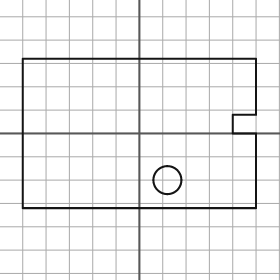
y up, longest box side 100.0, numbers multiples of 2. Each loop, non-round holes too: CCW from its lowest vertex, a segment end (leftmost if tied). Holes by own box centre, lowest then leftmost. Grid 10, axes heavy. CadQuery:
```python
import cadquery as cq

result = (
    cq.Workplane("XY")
    .moveTo(-50.0, -32.0)
    .lineTo(50.0, -32.0)
    .lineTo(50.0, 0.0)
    .lineTo(40.0, 0.0)
    .lineTo(40.0, 8.0)
    .lineTo(50.0, 8.0)
    .lineTo(50.0, 32.0)
    .lineTo(-50.0, 32.0)
    .close()
    .moveTo(12.0, -20.0)
    .circle(6.0)
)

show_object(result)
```